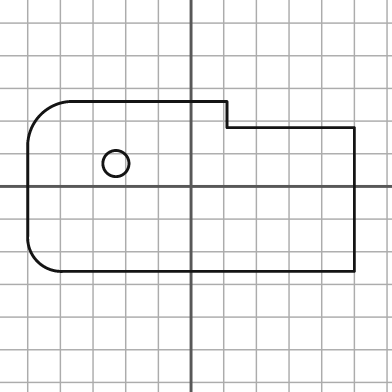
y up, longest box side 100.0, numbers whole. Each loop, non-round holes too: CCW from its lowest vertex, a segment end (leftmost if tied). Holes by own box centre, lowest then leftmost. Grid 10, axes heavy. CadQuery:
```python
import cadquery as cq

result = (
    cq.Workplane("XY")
    .moveTo(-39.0, -26.0)
    .lineTo(50.0, -26.0)
    .lineTo(50.0, 18.0)
    .lineTo(11.0, 18.0)
    .lineTo(11.0, 26.0)
    .lineTo(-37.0, 26.0)
    .threePointArc((-46.0, 22.0), (-50.0, 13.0))
    .lineTo(-50.0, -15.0)
    .threePointArc((-47.0, -23.0), (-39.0, -26.0))
    .close()
    .moveTo(-23.0, 7.0)
    .circle(4.0)
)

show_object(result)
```